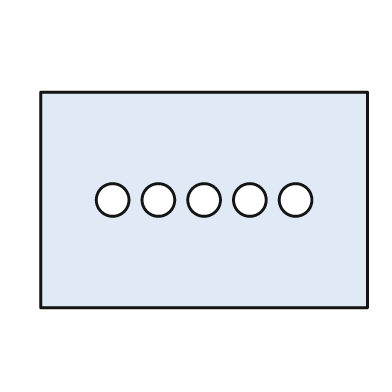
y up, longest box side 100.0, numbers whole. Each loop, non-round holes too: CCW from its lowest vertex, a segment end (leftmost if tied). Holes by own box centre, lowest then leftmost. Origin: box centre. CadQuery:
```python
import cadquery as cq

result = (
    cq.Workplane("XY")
    .moveTo(-50.0, -33.0)
    .lineTo(50.0, -33.0)
    .lineTo(50.0, 33.0)
    .lineTo(-50.0, 33.0)
    .close()
    .moveTo(-28.0, 0.0)
    .circle(5.0)
    .moveTo(-14.0, 0.0)
    .circle(5.0)
    .moveTo(0.0, 0.0)
    .circle(5.0)
    .moveTo(14.0, 0.0)
    .circle(5.0)
    .moveTo(28.0, 0.0)
    .circle(5.0)
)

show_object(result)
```